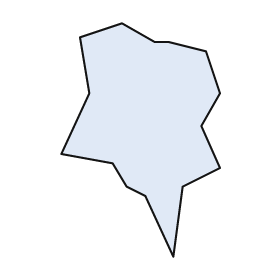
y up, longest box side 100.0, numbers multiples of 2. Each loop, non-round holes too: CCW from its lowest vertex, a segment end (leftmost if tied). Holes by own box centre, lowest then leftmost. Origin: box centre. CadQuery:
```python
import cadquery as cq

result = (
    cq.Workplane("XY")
    .moveTo(14.0, -50.0)
    .lineTo(18.0, -20.0)
    .lineTo(34.0, -12.0)
    .lineTo(26.0, 6.0)
    .lineTo(34.0, 20.0)
    .lineTo(28.0, 38.0)
    .lineTo(12.0, 42.0)
    .lineTo(6.0, 42.0)
    .lineTo(-8.0, 50.0)
    .lineTo(-26.0, 44.0)
    .lineTo(-22.0, 20.0)
    .lineTo(-34.0, -6.0)
    .lineTo(-12.0, -10.0)
    .lineTo(-6.0, -20.0)
    .lineTo(2.0, -24.0)
    .close()
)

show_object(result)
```